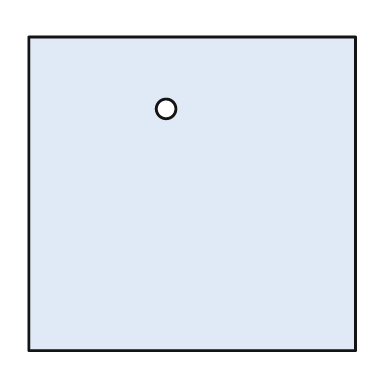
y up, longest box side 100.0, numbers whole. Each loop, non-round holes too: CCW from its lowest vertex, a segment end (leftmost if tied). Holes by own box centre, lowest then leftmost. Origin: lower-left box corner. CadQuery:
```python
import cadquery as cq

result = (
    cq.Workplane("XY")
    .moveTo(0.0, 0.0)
    .lineTo(100.0, 0.0)
    .lineTo(100.0, 96.0)
    .lineTo(0.0, 96.0)
    .close()
    .moveTo(42.0, 74.0)
    .circle(3.0)
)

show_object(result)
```